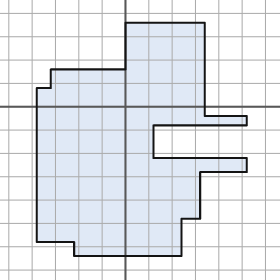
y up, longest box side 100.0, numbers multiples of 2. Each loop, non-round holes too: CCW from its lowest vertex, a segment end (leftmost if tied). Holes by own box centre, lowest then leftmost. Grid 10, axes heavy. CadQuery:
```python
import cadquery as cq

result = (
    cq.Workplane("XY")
    .moveTo(-22.0, -64.0)
    .lineTo(24.0, -64.0)
    .lineTo(24.0, -48.0)
    .lineTo(32.0, -48.0)
    .lineTo(32.0, -28.0)
    .lineTo(52.0, -28.0)
    .lineTo(52.0, -22.0)
    .lineTo(12.0, -22.0)
    .lineTo(12.0, -8.0)
    .lineTo(52.0, -8.0)
    .lineTo(52.0, -4.0)
    .lineTo(34.0, -4.0)
    .lineTo(34.0, 36.0)
    .lineTo(0.0, 36.0)
    .lineTo(0.0, 16.0)
    .lineTo(-32.0, 16.0)
    .lineTo(-32.0, 8.0)
    .lineTo(-38.0, 8.0)
    .lineTo(-38.0, -58.0)
    .lineTo(-22.0, -58.0)
    .close()
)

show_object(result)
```